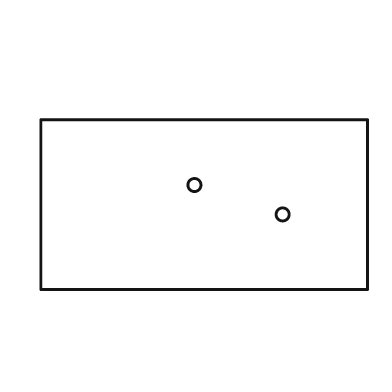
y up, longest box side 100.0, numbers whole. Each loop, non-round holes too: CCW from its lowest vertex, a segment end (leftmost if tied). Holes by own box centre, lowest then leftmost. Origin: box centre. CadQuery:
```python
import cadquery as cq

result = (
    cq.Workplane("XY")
    .moveTo(-50.0, -26.0)
    .lineTo(50.0, -26.0)
    .lineTo(50.0, 26.0)
    .lineTo(-50.0, 26.0)
    .close()
    .moveTo(24.0, -3.0)
    .circle(2.0)
    .moveTo(-3.0, 6.0)
    .circle(2.0)
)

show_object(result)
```